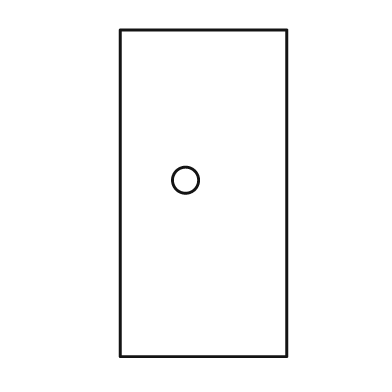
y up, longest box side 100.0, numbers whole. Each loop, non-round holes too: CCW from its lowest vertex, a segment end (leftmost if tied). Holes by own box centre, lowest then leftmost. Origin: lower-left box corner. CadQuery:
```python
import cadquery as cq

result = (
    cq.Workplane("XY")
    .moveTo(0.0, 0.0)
    .lineTo(51.0, 0.0)
    .lineTo(51.0, 100.0)
    .lineTo(0.0, 100.0)
    .close()
    .moveTo(20.0, 54.0)
    .circle(4.0)
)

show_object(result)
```